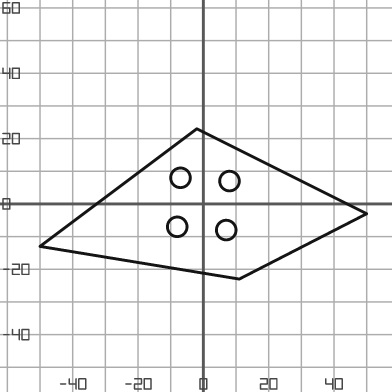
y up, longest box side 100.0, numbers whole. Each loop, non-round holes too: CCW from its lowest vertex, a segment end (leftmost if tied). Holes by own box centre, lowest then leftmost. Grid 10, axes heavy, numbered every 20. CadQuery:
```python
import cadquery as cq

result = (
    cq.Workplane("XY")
    .moveTo(11.0, -23.0)
    .lineTo(50.0, -3.0)
    .lineTo(-2.0, 23.0)
    .lineTo(-50.0, -13.0)
    .close()
    .moveTo(7.0, -8.0)
    .circle(3.0)
    .moveTo(-8.0, -7.0)
    .circle(3.0)
    .moveTo(8.0, 7.0)
    .circle(3.0)
    .moveTo(-7.0, 8.0)
    .circle(3.0)
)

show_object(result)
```